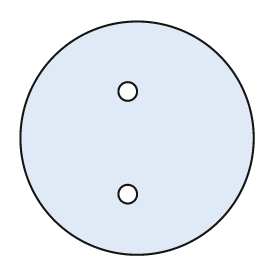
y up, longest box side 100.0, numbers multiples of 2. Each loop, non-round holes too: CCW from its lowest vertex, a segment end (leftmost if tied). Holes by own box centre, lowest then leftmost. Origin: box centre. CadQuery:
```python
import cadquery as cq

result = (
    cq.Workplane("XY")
    .moveTo(0.0, 0.0)
    .circle(50.0)
    .moveTo(-4.0, -24.0)
    .circle(4.0)
    .moveTo(-4.0, 20.0)
    .circle(4.0)
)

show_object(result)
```